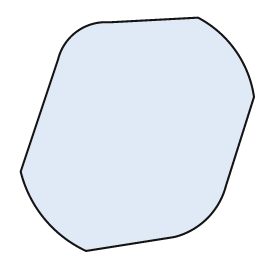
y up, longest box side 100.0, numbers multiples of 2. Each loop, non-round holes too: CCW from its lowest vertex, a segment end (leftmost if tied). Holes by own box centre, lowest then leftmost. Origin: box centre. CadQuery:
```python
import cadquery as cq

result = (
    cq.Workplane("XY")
    .moveTo(-22.0, -50.0)
    .lineTo(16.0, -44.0)
    .threePointArc((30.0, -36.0), (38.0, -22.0))
    .lineTo(50.0, 16.0)
    .threePointArc((42.0, 36.0), (26.0, 50.0))
    .lineTo(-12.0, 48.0)
    .threePointArc((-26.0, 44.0), (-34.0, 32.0))
    .lineTo(-50.0, -16.0)
    .threePointArc((-40.0, -36.0), (-22.0, -50.0))
    .close()
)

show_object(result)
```